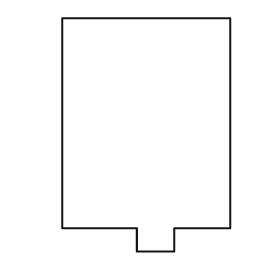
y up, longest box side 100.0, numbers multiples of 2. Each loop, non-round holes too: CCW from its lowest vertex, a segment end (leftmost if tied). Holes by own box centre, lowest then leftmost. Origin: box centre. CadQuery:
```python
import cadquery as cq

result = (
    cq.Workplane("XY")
    .moveTo(-4.0, -50.0)
    .lineTo(12.0, -50.0)
    .lineTo(12.0, -40.0)
    .lineTo(36.0, -40.0)
    .lineTo(36.0, 50.0)
    .lineTo(-36.0, 50.0)
    .lineTo(-36.0, -40.0)
    .lineTo(-4.0, -40.0)
    .close()
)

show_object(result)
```